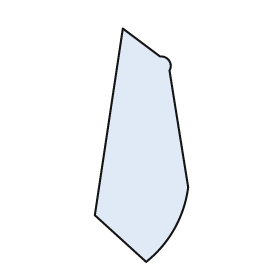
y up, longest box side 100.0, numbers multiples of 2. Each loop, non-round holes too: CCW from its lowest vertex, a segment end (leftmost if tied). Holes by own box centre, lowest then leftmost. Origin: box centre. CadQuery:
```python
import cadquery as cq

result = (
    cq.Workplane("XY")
    .moveTo(2.0, -50.0)
    .threePointArc((14.0, -36.0), (20.0, -18.0))
    .lineTo(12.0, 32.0)
    .threePointArc((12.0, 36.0), (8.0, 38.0))
    .lineTo(-8.0, 50.0)
    .lineTo(-20.0, -30.0)
    .close()
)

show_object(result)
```